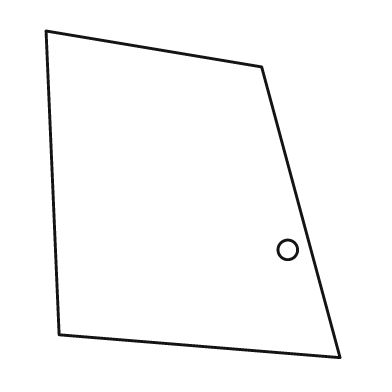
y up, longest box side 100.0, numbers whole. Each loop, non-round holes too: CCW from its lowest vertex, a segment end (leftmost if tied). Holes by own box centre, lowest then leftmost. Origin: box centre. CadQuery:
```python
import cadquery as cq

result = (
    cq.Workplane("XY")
    .moveTo(45.0, -50.0)
    .lineTo(21.0, 39.0)
    .lineTo(-45.0, 50.0)
    .lineTo(-41.0, -43.0)
    .close()
    .moveTo(29.0, -17.0)
    .circle(3.0)
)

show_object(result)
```